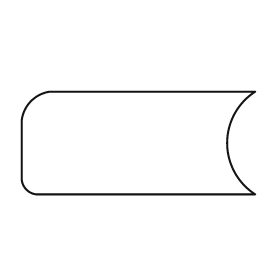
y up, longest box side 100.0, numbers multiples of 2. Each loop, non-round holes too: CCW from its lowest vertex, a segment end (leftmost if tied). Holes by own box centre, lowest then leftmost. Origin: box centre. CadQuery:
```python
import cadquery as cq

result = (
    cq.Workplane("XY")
    .moveTo(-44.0, -22.0)
    .lineTo(50.0, -22.0)
    .threePointArc((38.0, 0.0), (50.0, 22.0))
    .lineTo(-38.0, 22.0)
    .threePointArc((-46.0, 18.0), (-50.0, 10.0))
    .lineTo(-50.0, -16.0)
    .threePointArc((-48.0, -20.0), (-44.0, -22.0))
    .close()
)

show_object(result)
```